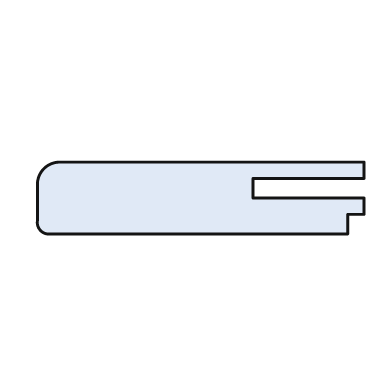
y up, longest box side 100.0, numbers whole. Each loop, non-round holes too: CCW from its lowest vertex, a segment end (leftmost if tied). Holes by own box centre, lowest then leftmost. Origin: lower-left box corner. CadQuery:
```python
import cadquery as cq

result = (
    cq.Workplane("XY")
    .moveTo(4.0, 0.0)
    .lineTo(95.0, 0.0)
    .lineTo(95.0, 6.0)
    .lineTo(100.0, 6.0)
    .lineTo(100.0, 11.0)
    .lineTo(66.0, 11.0)
    .lineTo(66.0, 17.0)
    .lineTo(100.0, 17.0)
    .lineTo(100.0, 22.0)
    .lineTo(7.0, 22.0)
    .threePointArc((2.0, 20.0), (0.0, 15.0))
    .lineTo(0.0, 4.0)
    .threePointArc((1.0, 1.0), (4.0, 0.0))
    .close()
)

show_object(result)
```